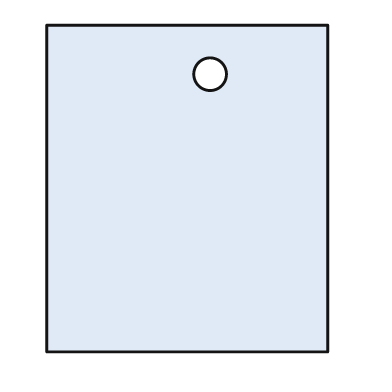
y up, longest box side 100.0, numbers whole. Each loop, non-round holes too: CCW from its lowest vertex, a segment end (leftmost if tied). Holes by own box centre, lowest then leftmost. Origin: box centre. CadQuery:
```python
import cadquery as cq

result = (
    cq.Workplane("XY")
    .moveTo(-43.0, -50.0)
    .lineTo(43.0, -50.0)
    .lineTo(43.0, 50.0)
    .lineTo(-43.0, 50.0)
    .close()
    .moveTo(7.0, 35.0)
    .circle(5.0)
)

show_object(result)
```